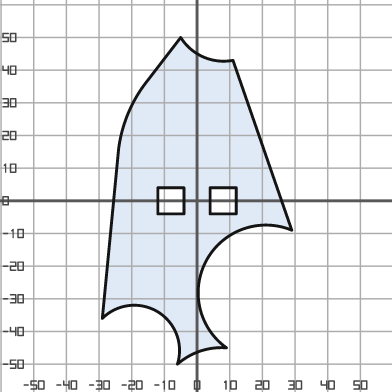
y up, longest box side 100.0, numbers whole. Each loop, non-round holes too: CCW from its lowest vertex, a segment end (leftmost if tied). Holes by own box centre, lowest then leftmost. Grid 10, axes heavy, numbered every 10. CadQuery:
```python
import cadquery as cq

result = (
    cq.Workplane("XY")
    .moveTo(-6.0, -50.0)
    .threePointArc((1.0, -46.0), (9.0, -45.0))
    .threePointArc((3.0, -18.0), (29.0, -9.0))
    .lineTo(11.0, 43.0)
    .threePointArc((2.0, 44.0), (-5.0, 50.0))
    .lineTo(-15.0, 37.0)
    .threePointArc((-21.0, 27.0), (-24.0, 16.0))
    .lineTo(-29.0, -36.0)
    .threePointArc((-12.0, -34.0), (-6.0, -50.0))
    .close()
    .moveTo(-12.0, -4.0)
    .lineTo(-4.0, -4.0)
    .lineTo(-4.0, 4.0)
    .lineTo(-12.0, 4.0)
    .close()
    .moveTo(4.0, -4.0)
    .lineTo(12.0, -4.0)
    .lineTo(12.0, 4.0)
    .lineTo(4.0, 4.0)
    .close()
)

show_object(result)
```